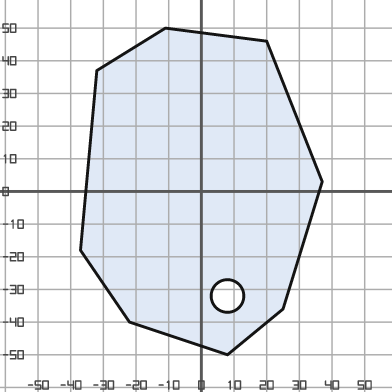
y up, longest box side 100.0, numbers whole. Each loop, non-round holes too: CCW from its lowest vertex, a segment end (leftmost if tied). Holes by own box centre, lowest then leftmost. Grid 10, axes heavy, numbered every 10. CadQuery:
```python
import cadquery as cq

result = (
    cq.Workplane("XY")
    .moveTo(8.0, -50.0)
    .lineTo(25.0, -36.0)
    .lineTo(37.0, 3.0)
    .lineTo(20.0, 46.0)
    .lineTo(-11.0, 50.0)
    .lineTo(-32.0, 37.0)
    .lineTo(-37.0, -18.0)
    .lineTo(-22.0, -40.0)
    .close()
    .moveTo(8.0, -32.0)
    .circle(5.0)
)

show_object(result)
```